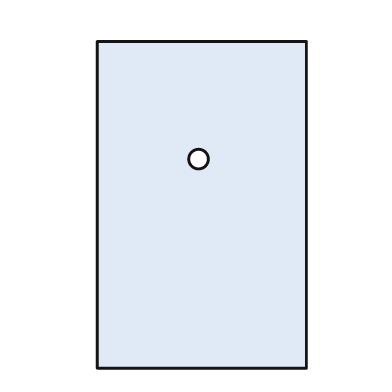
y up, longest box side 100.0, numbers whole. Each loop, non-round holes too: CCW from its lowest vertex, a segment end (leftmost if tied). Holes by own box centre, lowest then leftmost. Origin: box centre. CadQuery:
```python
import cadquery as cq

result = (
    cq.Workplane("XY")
    .moveTo(-32.0, -50.0)
    .lineTo(32.0, -50.0)
    .lineTo(32.0, 50.0)
    .lineTo(-32.0, 50.0)
    .close()
    .moveTo(-1.0, 14.0)
    .circle(3.0)
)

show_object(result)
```